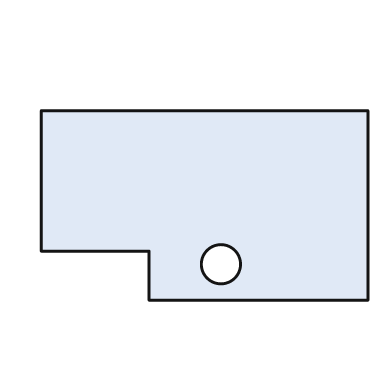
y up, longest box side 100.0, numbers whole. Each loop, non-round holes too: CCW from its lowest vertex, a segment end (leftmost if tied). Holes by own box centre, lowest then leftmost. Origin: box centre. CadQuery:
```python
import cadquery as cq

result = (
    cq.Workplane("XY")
    .moveTo(-17.0, -29.0)
    .lineTo(50.0, -29.0)
    .lineTo(50.0, 29.0)
    .lineTo(-50.0, 29.0)
    .lineTo(-50.0, -14.0)
    .lineTo(-17.0, -14.0)
    .close()
    .moveTo(5.0, -18.0)
    .circle(6.0)
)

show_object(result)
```